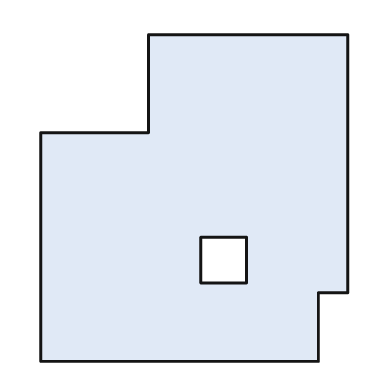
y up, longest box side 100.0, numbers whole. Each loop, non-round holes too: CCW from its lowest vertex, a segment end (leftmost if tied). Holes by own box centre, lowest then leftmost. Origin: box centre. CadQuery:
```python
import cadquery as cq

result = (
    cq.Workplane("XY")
    .moveTo(-47.0, -50.0)
    .lineTo(38.0, -50.0)
    .lineTo(38.0, -29.0)
    .lineTo(47.0, -29.0)
    .lineTo(47.0, 50.0)
    .lineTo(-14.0, 50.0)
    .lineTo(-14.0, 20.0)
    .lineTo(-47.0, 20.0)
    .close()
    .moveTo(2.0, -26.0)
    .lineTo(16.0, -26.0)
    .lineTo(16.0, -12.0)
    .lineTo(2.0, -12.0)
    .close()
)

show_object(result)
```